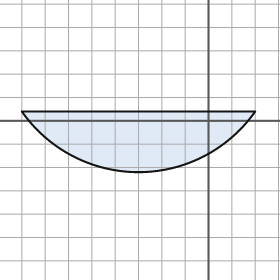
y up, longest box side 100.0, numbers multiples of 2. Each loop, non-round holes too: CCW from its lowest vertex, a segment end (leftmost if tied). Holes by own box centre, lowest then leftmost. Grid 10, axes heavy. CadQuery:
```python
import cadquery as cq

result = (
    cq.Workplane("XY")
    .moveTo(-80.0, 4.0)
    .threePointArc((-30.0, -22.0), (20.0, 4.0))
    .close()
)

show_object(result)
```